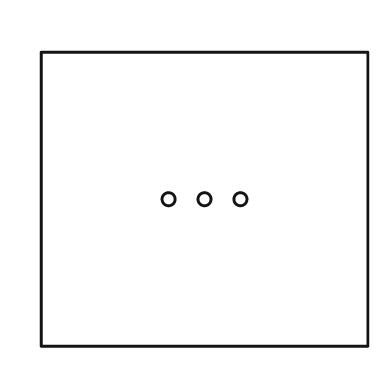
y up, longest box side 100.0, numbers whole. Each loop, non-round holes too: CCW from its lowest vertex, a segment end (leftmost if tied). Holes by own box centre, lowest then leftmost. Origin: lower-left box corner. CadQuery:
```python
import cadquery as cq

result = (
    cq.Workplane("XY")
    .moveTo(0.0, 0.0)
    .lineTo(100.0, 0.0)
    .lineTo(100.0, 90.0)
    .lineTo(0.0, 90.0)
    .close()
    .moveTo(39.0, 45.0)
    .circle(2.0)
    .moveTo(50.0, 45.0)
    .circle(2.0)
    .moveTo(61.0, 45.0)
    .circle(2.0)
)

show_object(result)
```